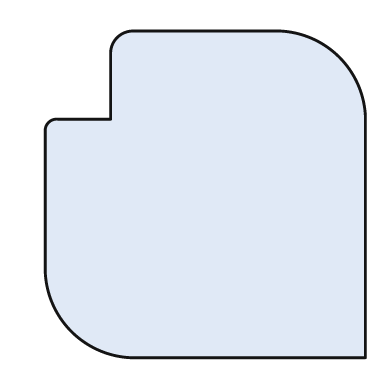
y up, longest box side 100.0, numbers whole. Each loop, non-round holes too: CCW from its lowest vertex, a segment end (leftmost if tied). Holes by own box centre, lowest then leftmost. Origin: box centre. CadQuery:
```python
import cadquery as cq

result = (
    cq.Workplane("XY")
    .moveTo(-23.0, -50.0)
    .lineTo(49.0, -50.0)
    .lineTo(49.0, 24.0)
    .threePointArc((41.0, 42.0), (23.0, 50.0))
    .lineTo(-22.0, 50.0)
    .threePointArc((-27.0, 48.0), (-29.0, 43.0))
    .lineTo(-29.0, 23.0)
    .lineTo(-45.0, 23.0)
    .threePointArc((-48.0, 22.0), (-49.0, 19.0))
    .lineTo(-49.0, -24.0)
    .threePointArc((-41.0, -42.0), (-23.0, -50.0))
    .close()
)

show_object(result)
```